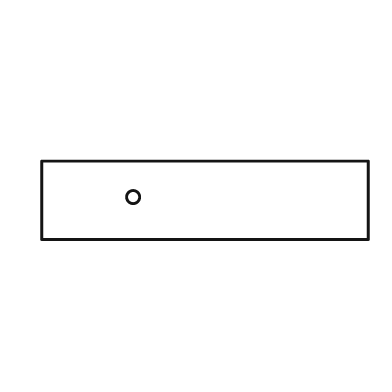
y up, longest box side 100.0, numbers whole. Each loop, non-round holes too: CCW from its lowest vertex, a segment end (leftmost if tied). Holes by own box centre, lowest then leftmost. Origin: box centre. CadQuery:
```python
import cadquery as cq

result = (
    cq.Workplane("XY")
    .moveTo(-50.0, -12.0)
    .lineTo(50.0, -12.0)
    .lineTo(50.0, 12.0)
    .lineTo(-50.0, 12.0)
    .close()
    .moveTo(-22.0, 1.0)
    .circle(2.0)
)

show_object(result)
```